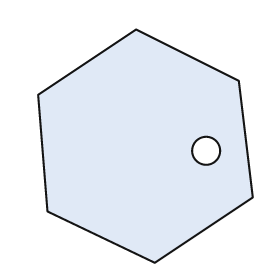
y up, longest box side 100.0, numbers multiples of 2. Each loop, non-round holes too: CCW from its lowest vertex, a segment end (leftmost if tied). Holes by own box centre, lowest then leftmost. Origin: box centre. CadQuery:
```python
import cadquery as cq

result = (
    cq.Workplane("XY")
    .moveTo(4.0, -50.0)
    .lineTo(46.0, -22.0)
    .lineTo(40.0, 28.0)
    .lineTo(-4.0, 50.0)
    .lineTo(-46.0, 22.0)
    .lineTo(-42.0, -28.0)
    .close()
    .moveTo(26.0, -2.0)
    .circle(6.0)
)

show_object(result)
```